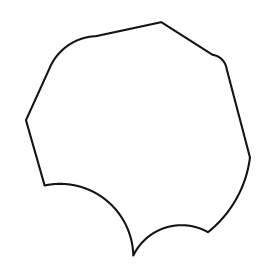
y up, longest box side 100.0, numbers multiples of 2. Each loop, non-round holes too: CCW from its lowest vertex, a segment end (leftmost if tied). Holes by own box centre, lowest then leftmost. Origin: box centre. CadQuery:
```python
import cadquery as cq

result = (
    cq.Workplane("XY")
    .moveTo(-2.0, -50.0)
    .threePointArc((12.0, -38.0), (30.0, -40.0))
    .threePointArc((42.0, -26.0), (48.0, -8.0))
    .lineTo(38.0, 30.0)
    .threePointArc((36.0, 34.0), (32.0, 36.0))
    .lineTo(10.0, 50.0)
    .lineTo(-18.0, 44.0)
    .threePointArc((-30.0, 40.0), (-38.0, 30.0))
    .lineTo(-48.0, 8.0)
    .lineTo(-40.0, -20.0)
    .threePointArc((-14.0, -26.0), (-2.0, -50.0))
    .close()
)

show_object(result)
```